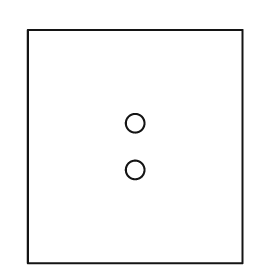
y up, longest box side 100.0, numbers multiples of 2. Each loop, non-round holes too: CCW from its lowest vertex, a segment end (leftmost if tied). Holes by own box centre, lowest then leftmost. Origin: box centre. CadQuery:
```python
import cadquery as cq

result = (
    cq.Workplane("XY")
    .moveTo(-46.0, -50.0)
    .lineTo(46.0, -50.0)
    .lineTo(46.0, 50.0)
    .lineTo(-46.0, 50.0)
    .close()
    .moveTo(0.0, -10.0)
    .circle(4.0)
    .moveTo(0.0, 10.0)
    .circle(4.0)
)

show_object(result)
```